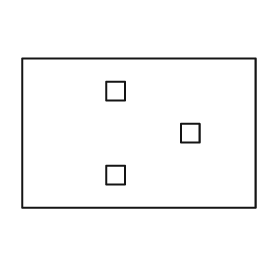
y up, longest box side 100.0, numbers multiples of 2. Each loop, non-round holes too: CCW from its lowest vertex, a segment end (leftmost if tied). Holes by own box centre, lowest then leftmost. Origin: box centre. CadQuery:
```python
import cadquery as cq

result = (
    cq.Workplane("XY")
    .moveTo(-50.0, -32.0)
    .lineTo(50.0, -32.0)
    .lineTo(50.0, 32.0)
    .lineTo(-50.0, 32.0)
    .close()
    .moveTo(-14.0, -22.0)
    .lineTo(-6.0, -22.0)
    .lineTo(-6.0, -14.0)
    .lineTo(-14.0, -14.0)
    .close()
    .moveTo(18.0, -4.0)
    .lineTo(26.0, -4.0)
    .lineTo(26.0, 4.0)
    .lineTo(18.0, 4.0)
    .close()
    .moveTo(-14.0, 14.0)
    .lineTo(-6.0, 14.0)
    .lineTo(-6.0, 22.0)
    .lineTo(-14.0, 22.0)
    .close()
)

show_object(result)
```